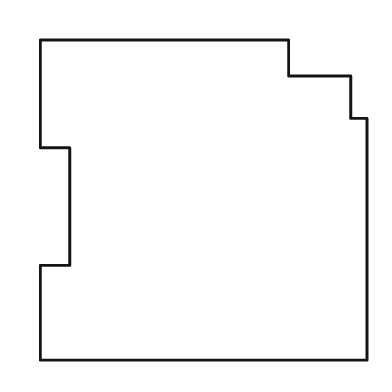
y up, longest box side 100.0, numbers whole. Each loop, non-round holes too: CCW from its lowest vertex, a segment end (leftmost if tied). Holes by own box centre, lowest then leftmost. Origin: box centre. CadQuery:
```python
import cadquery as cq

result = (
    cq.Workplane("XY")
    .moveTo(-50.0, -49.0)
    .lineTo(50.0, -49.0)
    .lineTo(50.0, 25.0)
    .lineTo(45.0, 25.0)
    .lineTo(45.0, 38.0)
    .lineTo(26.0, 38.0)
    .lineTo(26.0, 49.0)
    .lineTo(-50.0, 49.0)
    .lineTo(-50.0, 16.0)
    .lineTo(-41.0, 16.0)
    .lineTo(-41.0, -20.0)
    .lineTo(-50.0, -20.0)
    .close()
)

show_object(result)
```